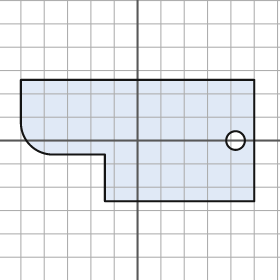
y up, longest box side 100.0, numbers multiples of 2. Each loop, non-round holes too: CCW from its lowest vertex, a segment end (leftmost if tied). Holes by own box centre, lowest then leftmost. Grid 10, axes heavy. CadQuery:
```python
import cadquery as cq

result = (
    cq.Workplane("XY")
    .moveTo(-14.0, -26.0)
    .lineTo(50.0, -26.0)
    .lineTo(50.0, 26.0)
    .lineTo(-50.0, 26.0)
    .lineTo(-50.0, 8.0)
    .threePointArc((-46.0, -2.0), (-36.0, -6.0))
    .lineTo(-14.0, -6.0)
    .close()
    .moveTo(42.0, 0.0)
    .circle(4.0)
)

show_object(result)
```